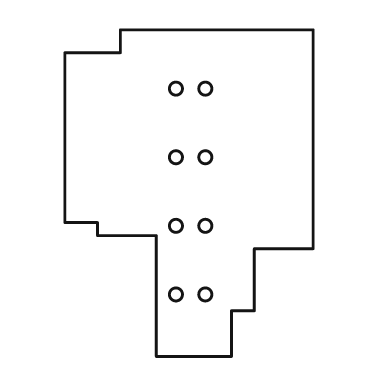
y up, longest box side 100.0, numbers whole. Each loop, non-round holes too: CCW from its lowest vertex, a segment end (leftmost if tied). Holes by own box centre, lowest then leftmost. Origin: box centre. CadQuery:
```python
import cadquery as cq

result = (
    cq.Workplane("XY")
    .moveTo(-10.0, -50.0)
    .lineTo(13.0, -50.0)
    .lineTo(13.0, -36.0)
    .lineTo(20.0, -36.0)
    .lineTo(20.0, -17.0)
    .lineTo(38.0, -17.0)
    .lineTo(38.0, 50.0)
    .lineTo(-21.0, 50.0)
    .lineTo(-21.0, 43.0)
    .lineTo(-38.0, 43.0)
    .lineTo(-38.0, -9.0)
    .lineTo(-28.0, -9.0)
    .lineTo(-28.0, -13.0)
    .lineTo(-10.0, -13.0)
    .close()
    .moveTo(-4.0, -31.0)
    .circle(2.0)
    .moveTo(5.0, -31.0)
    .circle(2.0)
    .moveTo(-4.0, -10.0)
    .circle(2.0)
    .moveTo(5.0, -10.0)
    .circle(2.0)
    .moveTo(-4.0, 11.0)
    .circle(2.0)
    .moveTo(5.0, 11.0)
    .circle(2.0)
    .moveTo(-4.0, 32.0)
    .circle(2.0)
    .moveTo(5.0, 32.0)
    .circle(2.0)
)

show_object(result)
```